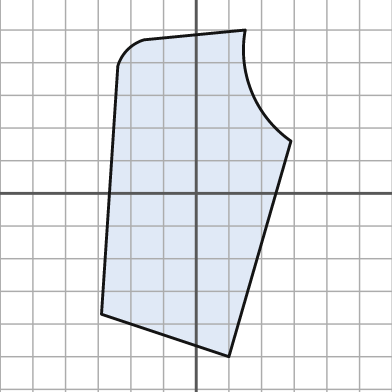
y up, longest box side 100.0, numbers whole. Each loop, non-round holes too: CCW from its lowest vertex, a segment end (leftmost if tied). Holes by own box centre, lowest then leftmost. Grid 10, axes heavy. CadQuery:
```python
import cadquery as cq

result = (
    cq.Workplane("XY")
    .moveTo(10.0, -50.0)
    .lineTo(29.0, 16.0)
    .threePointArc((17.0, 31.0), (15.0, 50.0))
    .lineTo(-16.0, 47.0)
    .threePointArc((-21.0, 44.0), (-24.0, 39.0))
    .lineTo(-29.0, -37.0)
    .close()
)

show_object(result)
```